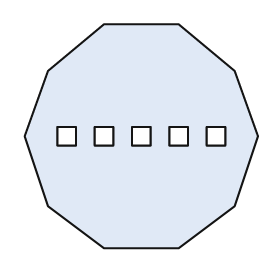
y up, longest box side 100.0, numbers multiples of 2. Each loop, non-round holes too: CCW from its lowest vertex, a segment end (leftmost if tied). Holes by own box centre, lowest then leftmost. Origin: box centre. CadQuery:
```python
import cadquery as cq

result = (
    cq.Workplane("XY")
    .moveTo(-16.0, -48.0)
    .lineTo(16.0, -48.0)
    .lineTo(40.0, -30.0)
    .lineTo(50.0, 0.0)
    .lineTo(40.0, 28.0)
    .lineTo(16.0, 48.0)
    .lineTo(-16.0, 48.0)
    .lineTo(-40.0, 28.0)
    .lineTo(-50.0, 0.0)
    .lineTo(-40.0, -30.0)
    .close()
    .moveTo(-36.0, -4.0)
    .lineTo(-28.0, -4.0)
    .lineTo(-28.0, 4.0)
    .lineTo(-36.0, 4.0)
    .close()
    .moveTo(-20.0, -4.0)
    .lineTo(-12.0, -4.0)
    .lineTo(-12.0, 4.0)
    .lineTo(-20.0, 4.0)
    .close()
    .moveTo(-4.0, -4.0)
    .lineTo(4.0, -4.0)
    .lineTo(4.0, 4.0)
    .lineTo(-4.0, 4.0)
    .close()
    .moveTo(12.0, -4.0)
    .lineTo(20.0, -4.0)
    .lineTo(20.0, 4.0)
    .lineTo(12.0, 4.0)
    .close()
    .moveTo(28.0, -4.0)
    .lineTo(36.0, -4.0)
    .lineTo(36.0, 4.0)
    .lineTo(28.0, 4.0)
    .close()
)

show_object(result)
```